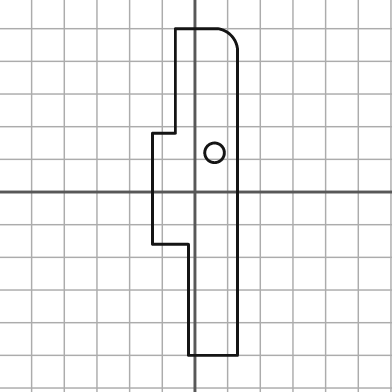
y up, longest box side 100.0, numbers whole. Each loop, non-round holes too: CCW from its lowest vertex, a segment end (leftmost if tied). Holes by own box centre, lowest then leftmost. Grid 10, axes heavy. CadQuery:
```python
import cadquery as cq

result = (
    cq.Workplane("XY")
    .moveTo(-2.0, -50.0)
    .lineTo(13.0, -50.0)
    .lineTo(13.0, 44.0)
    .threePointArc((11.0, 48.0), (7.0, 50.0))
    .lineTo(-6.0, 50.0)
    .lineTo(-6.0, 18.0)
    .lineTo(-13.0, 18.0)
    .lineTo(-13.0, -16.0)
    .lineTo(-2.0, -16.0)
    .close()
    .moveTo(6.0, 12.0)
    .circle(3.0)
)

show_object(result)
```